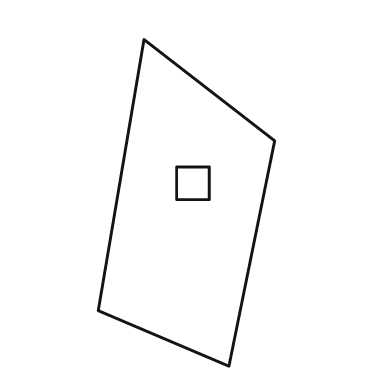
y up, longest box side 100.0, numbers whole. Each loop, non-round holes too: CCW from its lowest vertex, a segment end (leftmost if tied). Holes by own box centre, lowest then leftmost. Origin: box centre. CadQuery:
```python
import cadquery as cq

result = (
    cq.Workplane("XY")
    .moveTo(13.0, -50.0)
    .lineTo(27.0, 19.0)
    .lineTo(-13.0, 50.0)
    .lineTo(-27.0, -33.0)
    .close()
    .moveTo(-3.0, 1.0)
    .lineTo(7.0, 1.0)
    .lineTo(7.0, 11.0)
    .lineTo(-3.0, 11.0)
    .close()
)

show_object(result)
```